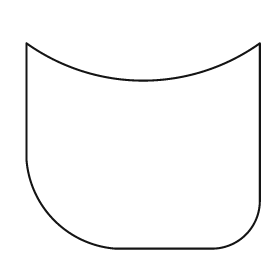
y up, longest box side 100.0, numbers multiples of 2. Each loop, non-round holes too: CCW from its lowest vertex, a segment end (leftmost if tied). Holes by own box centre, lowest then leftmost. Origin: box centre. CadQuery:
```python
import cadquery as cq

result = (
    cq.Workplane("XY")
    .moveTo(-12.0, -44.0)
    .lineTo(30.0, -44.0)
    .threePointArc((44.0, -38.0), (50.0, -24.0))
    .lineTo(50.0, 44.0)
    .threePointArc((0.0, 28.0), (-50.0, 44.0))
    .lineTo(-50.0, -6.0)
    .threePointArc((-38.0, -32.0), (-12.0, -44.0))
    .close()
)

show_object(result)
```